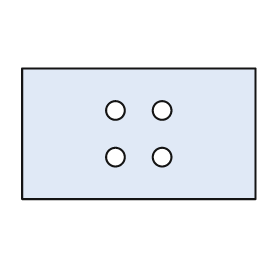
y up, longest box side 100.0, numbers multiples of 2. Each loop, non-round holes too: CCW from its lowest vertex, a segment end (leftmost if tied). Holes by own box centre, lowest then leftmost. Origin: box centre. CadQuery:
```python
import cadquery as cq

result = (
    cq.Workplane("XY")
    .moveTo(-50.0, -28.0)
    .lineTo(50.0, -28.0)
    .lineTo(50.0, 28.0)
    .lineTo(-50.0, 28.0)
    .close()
    .moveTo(-10.0, -10.0)
    .circle(4.0)
    .moveTo(10.0, -10.0)
    .circle(4.0)
    .moveTo(-10.0, 10.0)
    .circle(4.0)
    .moveTo(10.0, 10.0)
    .circle(4.0)
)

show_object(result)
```